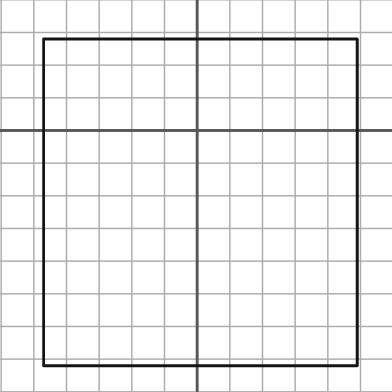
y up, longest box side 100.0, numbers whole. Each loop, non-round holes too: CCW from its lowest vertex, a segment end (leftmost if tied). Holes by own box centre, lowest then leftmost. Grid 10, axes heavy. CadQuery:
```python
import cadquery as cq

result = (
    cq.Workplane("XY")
    .moveTo(-47.0, -72.0)
    .lineTo(49.0, -72.0)
    .lineTo(49.0, 28.0)
    .lineTo(-47.0, 28.0)
    .close()
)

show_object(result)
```